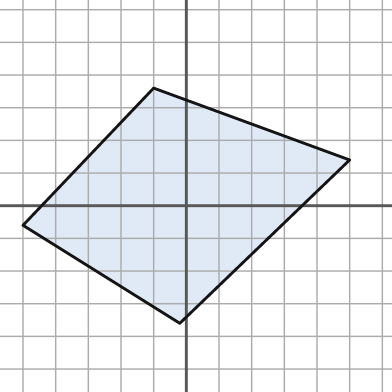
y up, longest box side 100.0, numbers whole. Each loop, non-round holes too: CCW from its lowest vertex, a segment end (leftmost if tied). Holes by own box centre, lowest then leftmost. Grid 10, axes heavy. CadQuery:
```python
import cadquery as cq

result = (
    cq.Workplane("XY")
    .moveTo(-2.0, -36.0)
    .lineTo(50.0, 14.0)
    .lineTo(-10.0, 36.0)
    .lineTo(-50.0, -6.0)
    .close()
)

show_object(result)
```